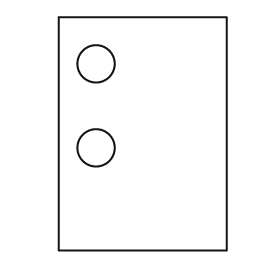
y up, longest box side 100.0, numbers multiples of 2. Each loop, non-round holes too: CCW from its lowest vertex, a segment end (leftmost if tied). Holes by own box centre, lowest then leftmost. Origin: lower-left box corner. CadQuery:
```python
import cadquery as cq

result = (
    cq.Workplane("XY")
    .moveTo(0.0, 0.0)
    .lineTo(72.0, 0.0)
    .lineTo(72.0, 100.0)
    .lineTo(0.0, 100.0)
    .close()
    .moveTo(16.0, 44.0)
    .circle(8.0)
    .moveTo(16.0, 80.0)
    .circle(8.0)
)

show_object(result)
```